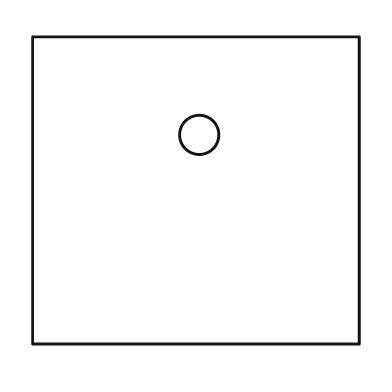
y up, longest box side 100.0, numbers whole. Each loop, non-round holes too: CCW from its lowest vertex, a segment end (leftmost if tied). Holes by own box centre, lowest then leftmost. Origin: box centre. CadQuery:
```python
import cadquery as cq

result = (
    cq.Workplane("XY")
    .moveTo(-50.0, -47.0)
    .lineTo(50.0, -47.0)
    .lineTo(50.0, 47.0)
    .lineTo(-50.0, 47.0)
    .close()
    .moveTo(1.0, 17.0)
    .circle(6.0)
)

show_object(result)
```